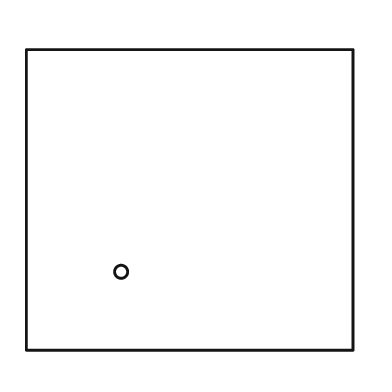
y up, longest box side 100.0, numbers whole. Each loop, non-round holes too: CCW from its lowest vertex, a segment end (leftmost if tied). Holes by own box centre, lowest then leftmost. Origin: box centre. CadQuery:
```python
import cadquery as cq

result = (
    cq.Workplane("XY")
    .moveTo(-50.0, -46.0)
    .lineTo(50.0, -46.0)
    .lineTo(50.0, 46.0)
    .lineTo(-50.0, 46.0)
    .close()
    .moveTo(-21.0, -22.0)
    .circle(2.0)
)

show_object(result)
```